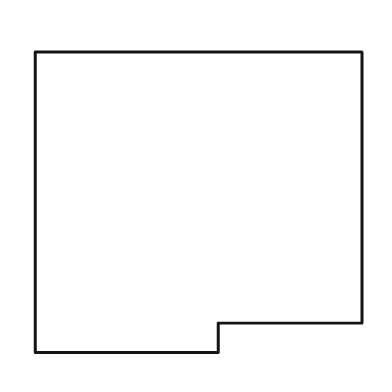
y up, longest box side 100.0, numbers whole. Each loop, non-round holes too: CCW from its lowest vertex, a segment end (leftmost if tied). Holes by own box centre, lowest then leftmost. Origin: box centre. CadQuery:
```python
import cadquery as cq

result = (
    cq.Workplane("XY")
    .moveTo(-50.0, -46.0)
    .lineTo(6.0, -46.0)
    .lineTo(6.0, -37.0)
    .lineTo(50.0, -37.0)
    .lineTo(50.0, 46.0)
    .lineTo(-50.0, 46.0)
    .close()
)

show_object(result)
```